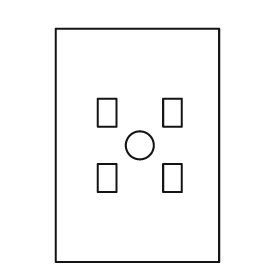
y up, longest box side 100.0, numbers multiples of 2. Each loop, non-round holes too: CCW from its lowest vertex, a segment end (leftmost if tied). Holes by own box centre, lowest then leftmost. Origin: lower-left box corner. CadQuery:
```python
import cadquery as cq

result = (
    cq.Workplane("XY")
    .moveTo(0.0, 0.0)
    .lineTo(70.0, 0.0)
    .lineTo(70.0, 100.0)
    .lineTo(0.0, 100.0)
    .close()
    .moveTo(18.0, 30.0)
    .lineTo(26.0, 30.0)
    .lineTo(26.0, 42.0)
    .lineTo(18.0, 42.0)
    .close()
    .moveTo(46.0, 30.0)
    .lineTo(54.0, 30.0)
    .lineTo(54.0, 42.0)
    .lineTo(46.0, 42.0)
    .close()
    .moveTo(36.0, 50.0)
    .circle(6.0)
    .moveTo(18.0, 58.0)
    .lineTo(26.0, 58.0)
    .lineTo(26.0, 70.0)
    .lineTo(18.0, 70.0)
    .close()
    .moveTo(46.0, 58.0)
    .lineTo(54.0, 58.0)
    .lineTo(54.0, 70.0)
    .lineTo(46.0, 70.0)
    .close()
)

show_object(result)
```